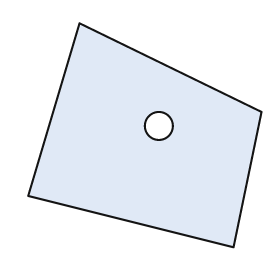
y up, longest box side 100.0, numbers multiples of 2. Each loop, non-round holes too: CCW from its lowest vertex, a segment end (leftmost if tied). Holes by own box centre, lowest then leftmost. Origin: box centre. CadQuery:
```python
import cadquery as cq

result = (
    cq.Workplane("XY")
    .moveTo(38.0, -48.0)
    .lineTo(50.0, 10.0)
    .lineTo(-28.0, 48.0)
    .lineTo(-50.0, -26.0)
    .close()
    .moveTo(6.0, 4.0)
    .circle(6.0)
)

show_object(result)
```